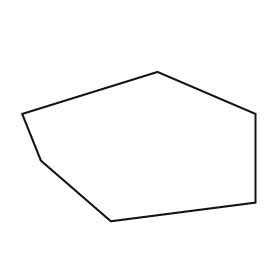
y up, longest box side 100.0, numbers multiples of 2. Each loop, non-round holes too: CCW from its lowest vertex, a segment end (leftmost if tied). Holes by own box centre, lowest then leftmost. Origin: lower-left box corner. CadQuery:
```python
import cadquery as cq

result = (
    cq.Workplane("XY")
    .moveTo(38.0, 0.0)
    .lineTo(100.0, 8.0)
    .lineTo(100.0, 46.0)
    .lineTo(58.0, 64.0)
    .lineTo(0.0, 46.0)
    .lineTo(8.0, 26.0)
    .close()
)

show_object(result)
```